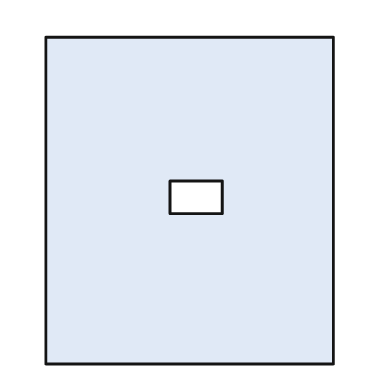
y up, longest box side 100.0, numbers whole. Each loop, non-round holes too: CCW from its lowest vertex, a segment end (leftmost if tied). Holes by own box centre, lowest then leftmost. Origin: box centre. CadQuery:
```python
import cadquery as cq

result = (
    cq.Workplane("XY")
    .moveTo(-44.0, -50.0)
    .lineTo(44.0, -50.0)
    .lineTo(44.0, 50.0)
    .lineTo(-44.0, 50.0)
    .close()
    .moveTo(-6.0, -4.0)
    .lineTo(10.0, -4.0)
    .lineTo(10.0, 6.0)
    .lineTo(-6.0, 6.0)
    .close()
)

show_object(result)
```